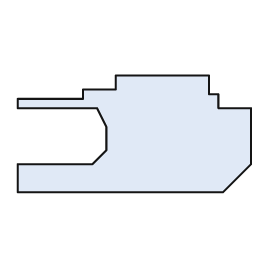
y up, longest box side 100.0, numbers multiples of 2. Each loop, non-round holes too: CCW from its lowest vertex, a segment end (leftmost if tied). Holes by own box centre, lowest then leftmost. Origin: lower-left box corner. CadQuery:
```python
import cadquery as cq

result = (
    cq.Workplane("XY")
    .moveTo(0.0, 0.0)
    .lineTo(88.0, 0.0)
    .lineTo(100.0, 12.0)
    .lineTo(100.0, 36.0)
    .lineTo(86.0, 36.0)
    .lineTo(86.0, 42.0)
    .lineTo(82.0, 42.0)
    .lineTo(82.0, 50.0)
    .lineTo(42.0, 50.0)
    .lineTo(42.0, 44.0)
    .lineTo(28.0, 44.0)
    .lineTo(28.0, 40.0)
    .lineTo(0.0, 40.0)
    .lineTo(0.0, 36.0)
    .lineTo(34.0, 36.0)
    .lineTo(38.0, 28.0)
    .lineTo(38.0, 18.0)
    .lineTo(32.0, 12.0)
    .lineTo(0.0, 12.0)
    .close()
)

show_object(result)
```